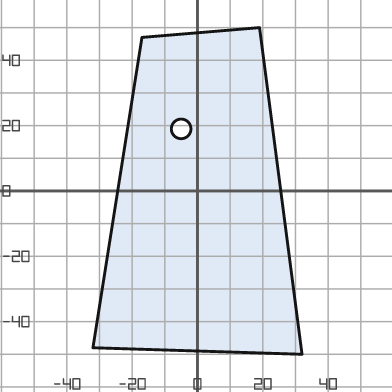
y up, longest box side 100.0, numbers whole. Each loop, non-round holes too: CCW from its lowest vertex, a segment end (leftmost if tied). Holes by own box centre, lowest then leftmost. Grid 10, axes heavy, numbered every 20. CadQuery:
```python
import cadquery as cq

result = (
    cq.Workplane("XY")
    .moveTo(32.0, -50.0)
    .lineTo(19.0, 50.0)
    .lineTo(-17.0, 47.0)
    .lineTo(-32.0, -48.0)
    .close()
    .moveTo(-5.0, 19.0)
    .circle(3.0)
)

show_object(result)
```